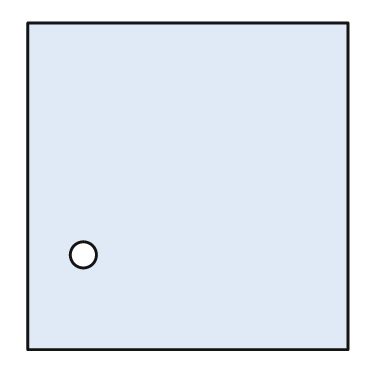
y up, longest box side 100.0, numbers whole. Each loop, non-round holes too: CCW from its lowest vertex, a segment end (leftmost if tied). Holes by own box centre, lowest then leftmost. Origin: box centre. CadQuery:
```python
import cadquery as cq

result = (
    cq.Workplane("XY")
    .moveTo(-49.0, -50.0)
    .lineTo(49.0, -50.0)
    .lineTo(49.0, 50.0)
    .lineTo(-49.0, 50.0)
    .close()
    .moveTo(-32.0, -21.0)
    .circle(4.0)
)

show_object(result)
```